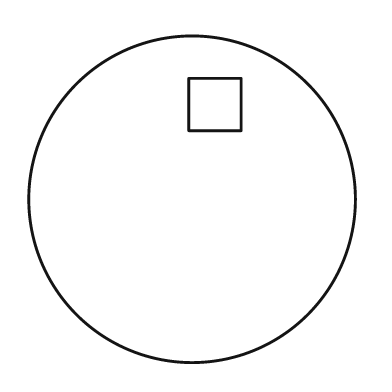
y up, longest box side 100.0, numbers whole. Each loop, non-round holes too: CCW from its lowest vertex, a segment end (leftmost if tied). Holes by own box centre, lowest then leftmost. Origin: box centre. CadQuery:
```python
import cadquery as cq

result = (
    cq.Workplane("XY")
    .moveTo(0.0, 0.0)
    .circle(50.0)
    .moveTo(-1.0, 21.0)
    .lineTo(15.0, 21.0)
    .lineTo(15.0, 37.0)
    .lineTo(-1.0, 37.0)
    .close()
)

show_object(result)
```